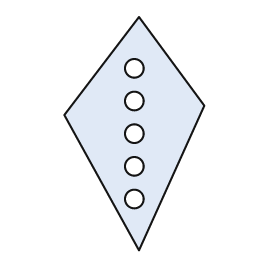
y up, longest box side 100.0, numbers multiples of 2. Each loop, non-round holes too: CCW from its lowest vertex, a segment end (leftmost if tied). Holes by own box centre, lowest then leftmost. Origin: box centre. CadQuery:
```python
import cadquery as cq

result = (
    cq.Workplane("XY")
    .moveTo(2.0, -50.0)
    .lineTo(30.0, 12.0)
    .lineTo(2.0, 50.0)
    .lineTo(-30.0, 8.0)
    .close()
    .moveTo(0.0, -28.0)
    .circle(4.0)
    .moveTo(0.0, -14.0)
    .circle(4.0)
    .moveTo(0.0, 0.0)
    .circle(4.0)
    .moveTo(0.0, 14.0)
    .circle(4.0)
    .moveTo(0.0, 28.0)
    .circle(4.0)
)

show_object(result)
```